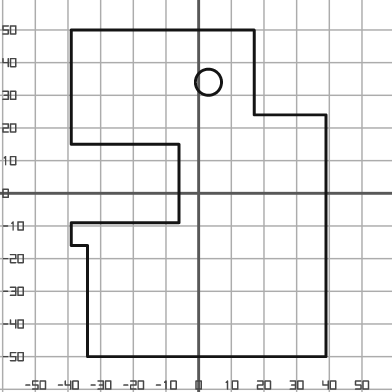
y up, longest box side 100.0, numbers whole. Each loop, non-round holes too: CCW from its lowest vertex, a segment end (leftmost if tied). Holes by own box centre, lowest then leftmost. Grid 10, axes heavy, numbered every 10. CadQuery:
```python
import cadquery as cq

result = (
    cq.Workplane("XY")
    .moveTo(-34.0, -50.0)
    .lineTo(39.0, -50.0)
    .lineTo(39.0, 24.0)
    .lineTo(17.0, 24.0)
    .lineTo(17.0, 50.0)
    .lineTo(-39.0, 50.0)
    .lineTo(-39.0, 15.0)
    .lineTo(-6.0, 15.0)
    .lineTo(-6.0, -9.0)
    .lineTo(-39.0, -9.0)
    .lineTo(-39.0, -16.0)
    .lineTo(-34.0, -16.0)
    .close()
    .moveTo(3.0, 34.0)
    .circle(4.0)
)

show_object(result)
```